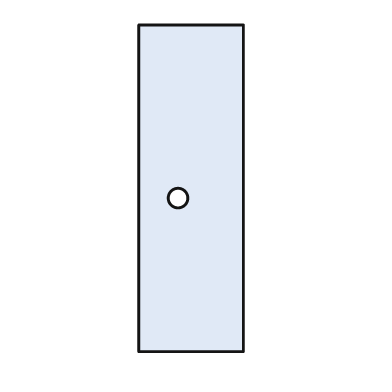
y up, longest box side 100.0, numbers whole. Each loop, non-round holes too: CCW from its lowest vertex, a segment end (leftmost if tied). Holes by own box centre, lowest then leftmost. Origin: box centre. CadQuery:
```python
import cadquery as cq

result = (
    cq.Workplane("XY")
    .moveTo(-16.0, -50.0)
    .lineTo(16.0, -50.0)
    .lineTo(16.0, 50.0)
    .lineTo(-16.0, 50.0)
    .close()
    .moveTo(-4.0, -3.0)
    .circle(3.0)
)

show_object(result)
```